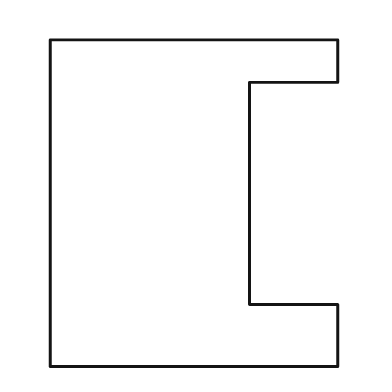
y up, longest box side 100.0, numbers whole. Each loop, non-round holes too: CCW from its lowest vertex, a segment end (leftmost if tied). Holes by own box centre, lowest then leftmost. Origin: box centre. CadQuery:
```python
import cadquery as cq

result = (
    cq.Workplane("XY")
    .moveTo(-44.0, -50.0)
    .lineTo(44.0, -50.0)
    .lineTo(44.0, -31.0)
    .lineTo(17.0, -31.0)
    .lineTo(17.0, 37.0)
    .lineTo(44.0, 37.0)
    .lineTo(44.0, 50.0)
    .lineTo(-44.0, 50.0)
    .close()
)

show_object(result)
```